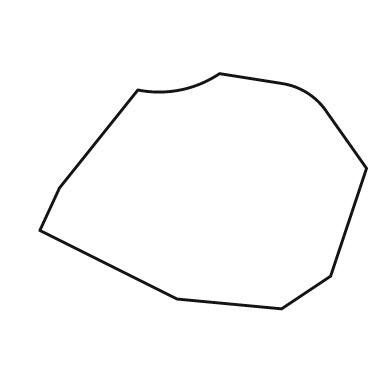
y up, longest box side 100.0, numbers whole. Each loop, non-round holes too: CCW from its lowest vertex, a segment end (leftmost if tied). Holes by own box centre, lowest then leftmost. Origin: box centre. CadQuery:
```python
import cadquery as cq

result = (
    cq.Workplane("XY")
    .moveTo(24.0, -36.0)
    .lineTo(39.0, -26.0)
    .lineTo(50.0, 7.0)
    .lineTo(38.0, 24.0)
    .threePointArc((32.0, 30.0), (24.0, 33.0))
    .lineTo(5.0, 36.0)
    .threePointArc((-7.0, 31.0), (-20.0, 31.0))
    .lineTo(-44.0, 1.0)
    .lineTo(-50.0, -12.0)
    .lineTo(-8.0, -33.0)
    .close()
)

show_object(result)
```